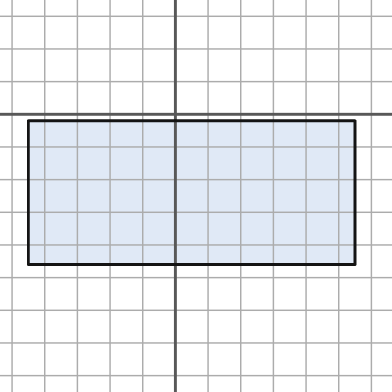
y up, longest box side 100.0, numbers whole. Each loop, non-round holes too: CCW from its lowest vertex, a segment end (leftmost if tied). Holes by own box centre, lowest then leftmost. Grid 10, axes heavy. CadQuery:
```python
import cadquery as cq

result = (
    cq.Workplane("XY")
    .moveTo(-45.0, -46.0)
    .lineTo(55.0, -46.0)
    .lineTo(55.0, -2.0)
    .lineTo(-45.0, -2.0)
    .close()
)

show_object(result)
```